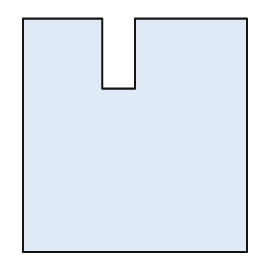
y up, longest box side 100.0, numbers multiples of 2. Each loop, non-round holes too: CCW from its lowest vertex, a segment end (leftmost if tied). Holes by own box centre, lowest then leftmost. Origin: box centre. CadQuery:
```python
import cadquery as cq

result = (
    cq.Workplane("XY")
    .moveTo(-48.0, -50.0)
    .lineTo(48.0, -50.0)
    .lineTo(48.0, 50.0)
    .lineTo(0.0, 50.0)
    .lineTo(0.0, 20.0)
    .lineTo(-14.0, 20.0)
    .lineTo(-14.0, 50.0)
    .lineTo(-48.0, 50.0)
    .close()
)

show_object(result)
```